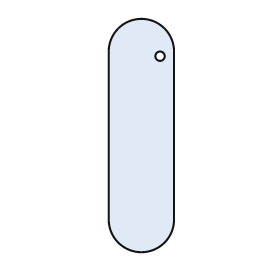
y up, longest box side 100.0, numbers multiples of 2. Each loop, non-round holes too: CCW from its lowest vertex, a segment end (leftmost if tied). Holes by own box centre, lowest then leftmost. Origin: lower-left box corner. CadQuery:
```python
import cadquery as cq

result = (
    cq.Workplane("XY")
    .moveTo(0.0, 14.0)
    .threePointArc((14.0, 0.0), (28.0, 14.0))
    .lineTo(28.0, 86.0)
    .threePointArc((14.0, 100.0), (0.0, 86.0))
    .close()
    .moveTo(22.0, 84.0)
    .circle(2.0)
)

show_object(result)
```